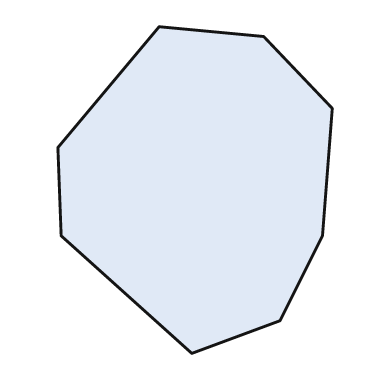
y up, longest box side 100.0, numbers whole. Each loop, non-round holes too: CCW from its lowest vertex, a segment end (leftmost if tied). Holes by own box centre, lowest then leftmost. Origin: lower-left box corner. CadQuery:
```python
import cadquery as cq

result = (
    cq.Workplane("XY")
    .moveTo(41.0, 0.0)
    .lineTo(68.0, 10.0)
    .lineTo(81.0, 36.0)
    .lineTo(84.0, 75.0)
    .lineTo(63.0, 97.0)
    .lineTo(31.0, 100.0)
    .lineTo(0.0, 63.0)
    .lineTo(1.0, 36.0)
    .close()
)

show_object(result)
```